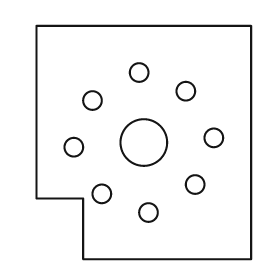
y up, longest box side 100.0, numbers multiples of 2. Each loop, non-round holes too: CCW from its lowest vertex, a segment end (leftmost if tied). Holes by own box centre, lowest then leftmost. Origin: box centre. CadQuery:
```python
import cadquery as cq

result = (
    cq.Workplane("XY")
    .moveTo(-26.0, -50.0)
    .lineTo(46.0, -50.0)
    .lineTo(46.0, 50.0)
    .lineTo(-46.0, 50.0)
    .lineTo(-46.0, -24.0)
    .lineTo(-26.0, -24.0)
    .close()
    .moveTo(2.0, -30.0)
    .circle(4.0)
    .moveTo(-18.0, -22.0)
    .circle(4.0)
    .moveTo(22.0, -18.0)
    .circle(4.0)
    .moveTo(-30.0, -2.0)
    .circle(4.0)
    .moveTo(0.0, 0.0)
    .circle(10.0)
    .moveTo(30.0, 2.0)
    .circle(4.0)
    .moveTo(-22.0, 18.0)
    .circle(4.0)
    .moveTo(18.0, 22.0)
    .circle(4.0)
    .moveTo(-2.0, 30.0)
    .circle(4.0)
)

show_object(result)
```